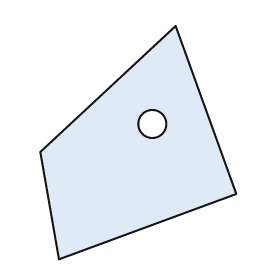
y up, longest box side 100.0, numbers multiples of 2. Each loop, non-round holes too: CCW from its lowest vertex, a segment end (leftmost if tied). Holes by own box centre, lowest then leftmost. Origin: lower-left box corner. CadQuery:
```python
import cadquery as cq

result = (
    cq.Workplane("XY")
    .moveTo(8.0, 0.0)
    .lineTo(84.0, 28.0)
    .lineTo(58.0, 100.0)
    .lineTo(0.0, 46.0)
    .close()
    .moveTo(48.0, 58.0)
    .circle(6.0)
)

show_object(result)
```